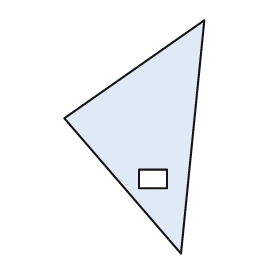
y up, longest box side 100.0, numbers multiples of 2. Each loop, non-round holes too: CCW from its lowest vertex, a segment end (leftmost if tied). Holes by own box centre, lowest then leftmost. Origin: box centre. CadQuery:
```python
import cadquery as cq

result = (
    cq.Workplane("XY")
    .moveTo(20.0, -50.0)
    .lineTo(30.0, 50.0)
    .lineTo(-30.0, 8.0)
    .close()
    .moveTo(2.0, -22.0)
    .lineTo(14.0, -22.0)
    .lineTo(14.0, -14.0)
    .lineTo(2.0, -14.0)
    .close()
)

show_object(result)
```